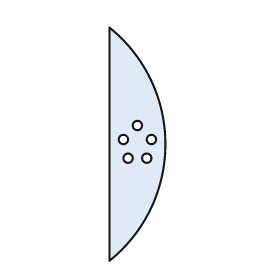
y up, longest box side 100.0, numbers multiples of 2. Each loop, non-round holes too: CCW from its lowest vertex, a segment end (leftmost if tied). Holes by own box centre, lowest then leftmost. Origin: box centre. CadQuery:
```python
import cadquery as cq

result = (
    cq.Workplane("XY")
    .moveTo(-12.0, -50.0)
    .threePointArc((12.0, 0.0), (-12.0, 50.0))
    .close()
    .moveTo(-4.0, -6.0)
    .circle(2.0)
    .moveTo(4.0, -6.0)
    .circle(2.0)
    .moveTo(-6.0, 2.0)
    .circle(2.0)
    .moveTo(6.0, 2.0)
    .circle(2.0)
    .moveTo(0.0, 8.0)
    .circle(2.0)
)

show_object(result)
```